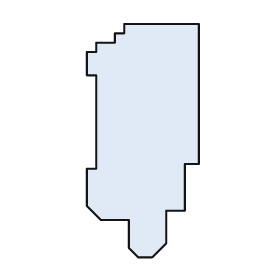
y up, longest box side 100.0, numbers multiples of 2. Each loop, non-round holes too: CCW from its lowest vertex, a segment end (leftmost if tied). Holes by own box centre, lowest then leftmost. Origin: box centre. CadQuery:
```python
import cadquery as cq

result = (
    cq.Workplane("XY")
    .moveTo(-2.0, -50.0)
    .lineTo(4.0, -50.0)
    .lineTo(10.0, -44.0)
    .lineTo(10.0, -30.0)
    .lineTo(18.0, -30.0)
    .lineTo(18.0, -10.0)
    .lineTo(24.0, -10.0)
    .lineTo(24.0, 50.0)
    .lineTo(-8.0, 50.0)
    .lineTo(-8.0, 46.0)
    .lineTo(-12.0, 46.0)
    .lineTo(-12.0, 42.0)
    .lineTo(-20.0, 42.0)
    .lineTo(-20.0, 38.0)
    .lineTo(-24.0, 38.0)
    .lineTo(-24.0, 28.0)
    .lineTo(-20.0, 28.0)
    .lineTo(-20.0, -12.0)
    .lineTo(-24.0, -12.0)
    .lineTo(-24.0, -28.0)
    .lineTo(-18.0, -34.0)
    .lineTo(-6.0, -34.0)
    .lineTo(-6.0, -46.0)
    .close()
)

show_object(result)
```